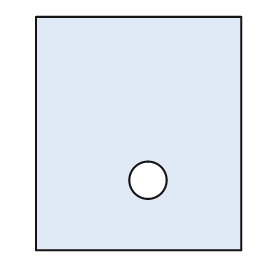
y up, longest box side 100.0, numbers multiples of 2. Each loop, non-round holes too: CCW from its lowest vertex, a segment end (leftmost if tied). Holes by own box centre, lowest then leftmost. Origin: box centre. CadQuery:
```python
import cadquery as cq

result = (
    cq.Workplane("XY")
    .moveTo(-44.0, -50.0)
    .lineTo(44.0, -50.0)
    .lineTo(44.0, 50.0)
    .lineTo(-44.0, 50.0)
    .close()
    .moveTo(4.0, -20.0)
    .circle(8.0)
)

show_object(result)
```